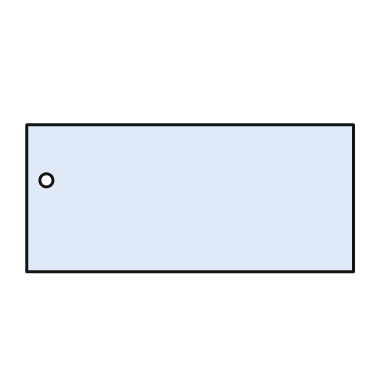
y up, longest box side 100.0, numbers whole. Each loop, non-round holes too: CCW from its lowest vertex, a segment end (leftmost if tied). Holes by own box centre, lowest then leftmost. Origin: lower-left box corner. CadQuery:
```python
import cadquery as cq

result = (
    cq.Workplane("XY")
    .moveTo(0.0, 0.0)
    .lineTo(100.0, 0.0)
    .lineTo(100.0, 45.0)
    .lineTo(0.0, 45.0)
    .close()
    .moveTo(6.0, 28.0)
    .circle(2.0)
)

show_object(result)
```